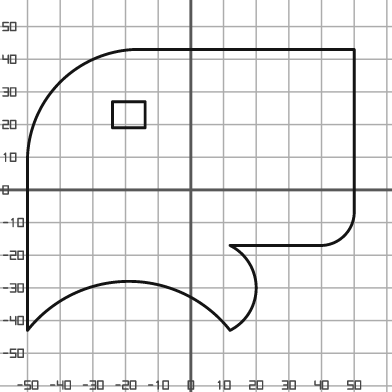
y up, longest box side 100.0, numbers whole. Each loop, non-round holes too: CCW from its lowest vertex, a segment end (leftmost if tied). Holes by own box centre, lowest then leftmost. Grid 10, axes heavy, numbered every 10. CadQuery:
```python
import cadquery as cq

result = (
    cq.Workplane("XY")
    .moveTo(-50.0, -43.0)
    .threePointArc((-19.0, -28.0), (12.0, -43.0))
    .threePointArc((20.0, -30.0), (12.0, -17.0))
    .lineTo(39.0, -17.0)
    .threePointArc((47.0, -14.0), (50.0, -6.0))
    .lineTo(50.0, 43.0)
    .lineTo(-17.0, 43.0)
    .threePointArc((-40.0, 33.0), (-50.0, 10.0))
    .close()
    .moveTo(-24.0, 19.0)
    .lineTo(-14.0, 19.0)
    .lineTo(-14.0, 27.0)
    .lineTo(-24.0, 27.0)
    .close()
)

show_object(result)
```